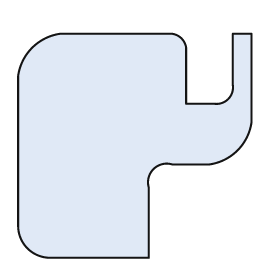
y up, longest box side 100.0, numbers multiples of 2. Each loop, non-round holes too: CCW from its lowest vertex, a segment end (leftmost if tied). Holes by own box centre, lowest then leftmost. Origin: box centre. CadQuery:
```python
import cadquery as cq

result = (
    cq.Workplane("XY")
    .moveTo(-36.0, -48.0)
    .lineTo(6.0, -48.0)
    .lineTo(6.0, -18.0)
    .threePointArc((8.0, -10.0), (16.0, -8.0))
    .lineTo(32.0, -8.0)
    .threePointArc((44.0, -2.0), (50.0, 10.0))
    .lineTo(50.0, 48.0)
    .lineTo(42.0, 48.0)
    .lineTo(42.0, 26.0)
    .threePointArc((40.0, 20.0), (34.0, 18.0))
    .lineTo(22.0, 18.0)
    .lineTo(22.0, 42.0)
    .threePointArc((20.0, 46.0), (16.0, 48.0))
    .lineTo(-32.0, 48.0)
    .threePointArc((-44.0, 42.0), (-50.0, 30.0))
    .lineTo(-50.0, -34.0)
    .threePointArc((-46.0, -44.0), (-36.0, -48.0))
    .close()
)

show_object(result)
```